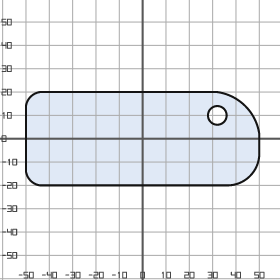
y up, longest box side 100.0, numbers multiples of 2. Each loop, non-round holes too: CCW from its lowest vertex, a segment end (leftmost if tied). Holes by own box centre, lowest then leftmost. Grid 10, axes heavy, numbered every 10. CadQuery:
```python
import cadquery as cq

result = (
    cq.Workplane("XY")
    .moveTo(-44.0, -20.0)
    .lineTo(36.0, -20.0)
    .threePointArc((46.0, -16.0), (50.0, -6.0))
    .lineTo(50.0, 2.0)
    .threePointArc((44.0, 14.0), (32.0, 20.0))
    .lineTo(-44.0, 20.0)
    .threePointArc((-48.0, 18.0), (-50.0, 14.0))
    .lineTo(-50.0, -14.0)
    .threePointArc((-48.0, -18.0), (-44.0, -20.0))
    .close()
    .moveTo(32.0, 10.0)
    .circle(4.0)
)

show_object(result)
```